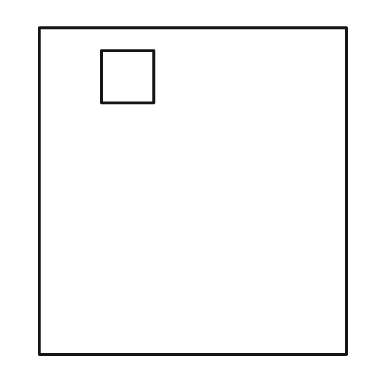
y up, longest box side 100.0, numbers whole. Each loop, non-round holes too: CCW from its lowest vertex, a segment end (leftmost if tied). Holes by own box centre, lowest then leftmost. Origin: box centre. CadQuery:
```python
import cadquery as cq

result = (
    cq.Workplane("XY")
    .moveTo(-47.0, -50.0)
    .lineTo(47.0, -50.0)
    .lineTo(47.0, 50.0)
    .lineTo(-47.0, 50.0)
    .close()
    .moveTo(-28.0, 27.0)
    .lineTo(-12.0, 27.0)
    .lineTo(-12.0, 43.0)
    .lineTo(-28.0, 43.0)
    .close()
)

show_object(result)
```